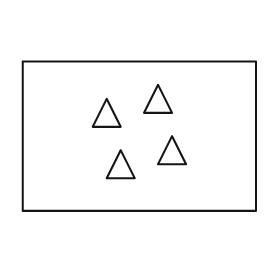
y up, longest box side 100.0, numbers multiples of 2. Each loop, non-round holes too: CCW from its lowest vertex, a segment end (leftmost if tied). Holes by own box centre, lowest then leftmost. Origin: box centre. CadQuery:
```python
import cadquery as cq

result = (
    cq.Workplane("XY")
    .moveTo(-50.0, -32.0)
    .lineTo(50.0, -32.0)
    .lineTo(50.0, 32.0)
    .lineTo(-50.0, 32.0)
    .close()
    .moveTo(-14.0, -18.0)
    .lineTo(-2.0, -18.0)
    .lineTo(-8.0, -6.0)
    .close()
    .moveTo(8.0, -12.0)
    .lineTo(20.0, -12.0)
    .lineTo(14.0, 0.0)
    .close()
    .moveTo(-20.0, 4.0)
    .lineTo(-8.0, 4.0)
    .lineTo(-14.0, 16.0)
    .close()
    .moveTo(2.0, 10.0)
    .lineTo(14.0, 10.0)
    .lineTo(8.0, 22.0)
    .close()
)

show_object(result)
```